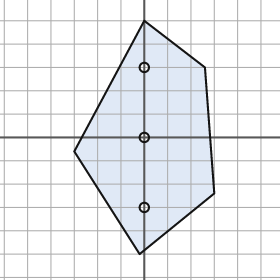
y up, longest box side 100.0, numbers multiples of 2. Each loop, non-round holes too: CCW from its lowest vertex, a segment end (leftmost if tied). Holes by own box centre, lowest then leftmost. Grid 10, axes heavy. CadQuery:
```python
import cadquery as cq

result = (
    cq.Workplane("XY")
    .moveTo(-2.0, -50.0)
    .lineTo(30.0, -24.0)
    .lineTo(26.0, 30.0)
    .lineTo(0.0, 50.0)
    .lineTo(-30.0, -6.0)
    .close()
    .moveTo(0.0, -30.0)
    .circle(2.0)
    .moveTo(0.0, 0.0)
    .circle(2.0)
    .moveTo(0.0, 30.0)
    .circle(2.0)
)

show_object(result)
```